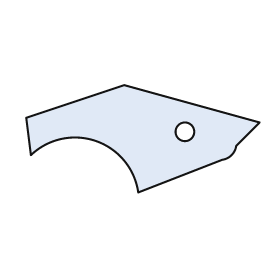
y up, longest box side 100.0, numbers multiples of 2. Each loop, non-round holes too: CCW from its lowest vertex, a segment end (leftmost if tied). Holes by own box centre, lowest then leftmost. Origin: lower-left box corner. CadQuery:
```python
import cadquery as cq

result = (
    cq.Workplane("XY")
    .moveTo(48.0, 0.0)
    .lineTo(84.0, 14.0)
    .threePointArc((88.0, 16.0), (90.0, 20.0))
    .lineTo(100.0, 30.0)
    .lineTo(42.0, 46.0)
    .lineTo(0.0, 32.0)
    .lineTo(2.0, 16.0)
    .threePointArc((30.0, 22.0), (48.0, 0.0))
    .close()
    .moveTo(68.0, 26.0)
    .circle(4.0)
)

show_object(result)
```